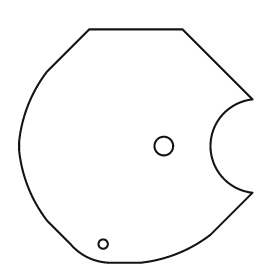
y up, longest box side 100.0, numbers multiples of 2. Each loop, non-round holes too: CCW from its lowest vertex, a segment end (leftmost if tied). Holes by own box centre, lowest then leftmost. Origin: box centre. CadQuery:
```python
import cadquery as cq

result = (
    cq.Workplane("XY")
    .moveTo(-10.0, -50.0)
    .lineTo(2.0, -50.0)
    .threePointArc((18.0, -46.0), (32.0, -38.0))
    .lineTo(50.0, -20.0)
    .threePointArc((32.0, 0.0), (50.0, 20.0))
    .lineTo(20.0, 50.0)
    .lineTo(-20.0, 50.0)
    .lineTo(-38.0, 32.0)
    .threePointArc((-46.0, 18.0), (-50.0, 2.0))
    .lineTo(-50.0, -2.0)
    .threePointArc((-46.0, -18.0), (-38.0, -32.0))
    .lineTo(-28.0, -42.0)
    .threePointArc((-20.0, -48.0), (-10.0, -50.0))
    .close()
    .moveTo(-14.0, -42.0)
    .circle(2.0)
    .moveTo(12.0, 0.0)
    .circle(4.0)
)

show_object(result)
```